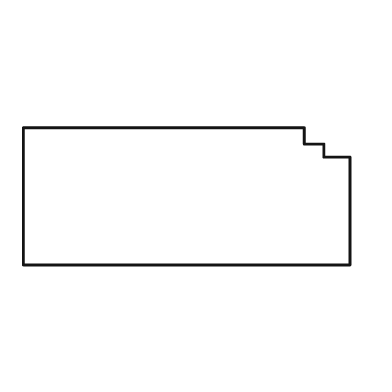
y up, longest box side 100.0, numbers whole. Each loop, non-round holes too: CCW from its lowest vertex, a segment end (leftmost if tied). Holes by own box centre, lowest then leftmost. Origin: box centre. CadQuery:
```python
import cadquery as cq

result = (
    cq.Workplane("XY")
    .moveTo(-50.0, -21.0)
    .lineTo(50.0, -21.0)
    .lineTo(50.0, 12.0)
    .lineTo(42.0, 12.0)
    .lineTo(42.0, 16.0)
    .lineTo(36.0, 16.0)
    .lineTo(36.0, 21.0)
    .lineTo(-50.0, 21.0)
    .close()
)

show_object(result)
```